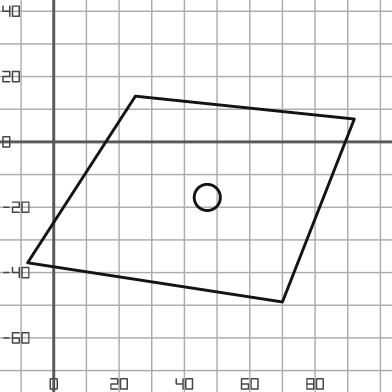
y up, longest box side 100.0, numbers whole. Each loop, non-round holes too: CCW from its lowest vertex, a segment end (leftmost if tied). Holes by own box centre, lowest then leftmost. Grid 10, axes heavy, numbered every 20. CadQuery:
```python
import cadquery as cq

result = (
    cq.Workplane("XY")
    .moveTo(70.0, -49.0)
    .lineTo(92.0, 7.0)
    .lineTo(25.0, 14.0)
    .lineTo(-8.0, -37.0)
    .close()
    .moveTo(47.0, -17.0)
    .circle(4.0)
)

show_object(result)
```